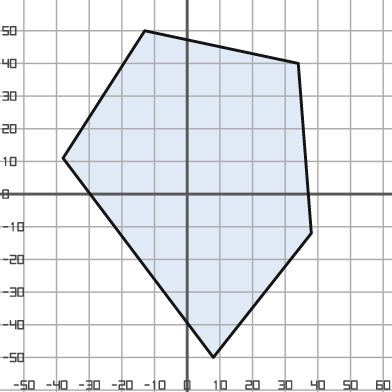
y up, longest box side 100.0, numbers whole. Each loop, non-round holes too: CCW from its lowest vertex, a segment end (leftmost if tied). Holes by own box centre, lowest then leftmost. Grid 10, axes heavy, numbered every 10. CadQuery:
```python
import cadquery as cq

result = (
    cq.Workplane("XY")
    .moveTo(8.0, -50.0)
    .lineTo(38.0, -12.0)
    .lineTo(34.0, 40.0)
    .lineTo(-13.0, 50.0)
    .lineTo(-38.0, 11.0)
    .close()
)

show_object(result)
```